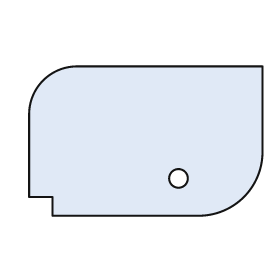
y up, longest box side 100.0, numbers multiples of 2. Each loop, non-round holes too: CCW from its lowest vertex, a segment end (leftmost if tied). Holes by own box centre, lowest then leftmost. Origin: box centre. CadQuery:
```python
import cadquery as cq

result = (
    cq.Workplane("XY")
    .moveTo(-40.0, -32.0)
    .lineTo(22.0, -32.0)
    .threePointArc((42.0, -24.0), (50.0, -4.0))
    .lineTo(50.0, 32.0)
    .lineTo(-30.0, 32.0)
    .threePointArc((-44.0, 26.0), (-50.0, 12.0))
    .lineTo(-50.0, -24.0)
    .lineTo(-40.0, -24.0)
    .close()
    .moveTo(14.0, -16.0)
    .circle(4.0)
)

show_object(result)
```